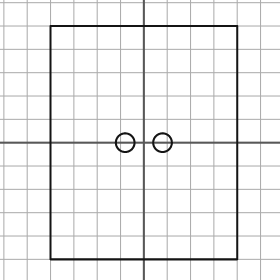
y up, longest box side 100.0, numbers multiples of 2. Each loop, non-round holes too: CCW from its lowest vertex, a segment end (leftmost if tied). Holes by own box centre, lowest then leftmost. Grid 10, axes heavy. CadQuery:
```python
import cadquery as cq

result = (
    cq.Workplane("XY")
    .moveTo(-40.0, -50.0)
    .lineTo(40.0, -50.0)
    .lineTo(40.0, 50.0)
    .lineTo(-40.0, 50.0)
    .close()
    .moveTo(-8.0, 0.0)
    .circle(4.0)
    .moveTo(8.0, 0.0)
    .circle(4.0)
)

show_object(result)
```